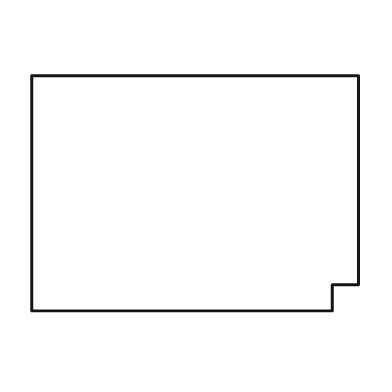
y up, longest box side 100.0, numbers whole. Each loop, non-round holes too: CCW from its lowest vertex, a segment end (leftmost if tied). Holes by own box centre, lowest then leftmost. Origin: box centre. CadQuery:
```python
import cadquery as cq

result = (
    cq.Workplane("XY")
    .moveTo(-50.0, -36.0)
    .lineTo(42.0, -36.0)
    .lineTo(42.0, -28.0)
    .lineTo(50.0, -28.0)
    .lineTo(50.0, 36.0)
    .lineTo(-50.0, 36.0)
    .close()
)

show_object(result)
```